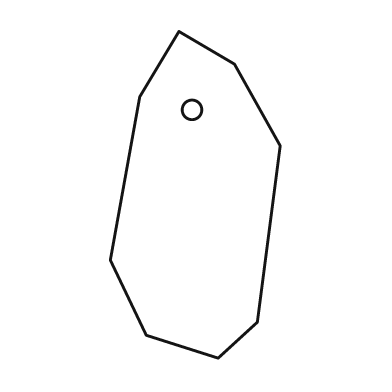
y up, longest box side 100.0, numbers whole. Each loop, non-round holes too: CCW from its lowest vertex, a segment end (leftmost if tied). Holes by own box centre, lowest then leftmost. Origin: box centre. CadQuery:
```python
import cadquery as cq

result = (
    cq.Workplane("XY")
    .moveTo(7.0, -50.0)
    .lineTo(19.0, -39.0)
    .lineTo(26.0, 15.0)
    .lineTo(12.0, 40.0)
    .lineTo(-5.0, 50.0)
    .lineTo(-17.0, 30.0)
    .lineTo(-26.0, -20.0)
    .lineTo(-15.0, -43.0)
    .close()
    .moveTo(-1.0, 26.0)
    .circle(3.0)
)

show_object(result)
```